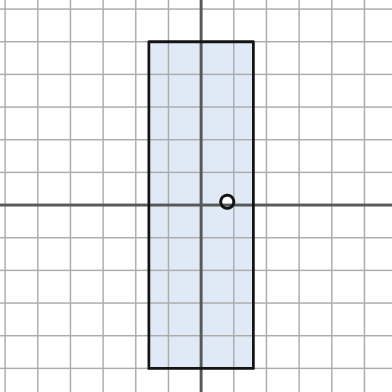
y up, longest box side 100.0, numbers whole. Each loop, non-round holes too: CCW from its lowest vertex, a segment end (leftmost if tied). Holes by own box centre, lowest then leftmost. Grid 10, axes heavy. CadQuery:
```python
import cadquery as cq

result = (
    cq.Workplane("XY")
    .moveTo(-16.0, -50.0)
    .lineTo(16.0, -50.0)
    .lineTo(16.0, 50.0)
    .lineTo(-16.0, 50.0)
    .close()
    .moveTo(8.0, 1.0)
    .circle(2.0)
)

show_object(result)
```